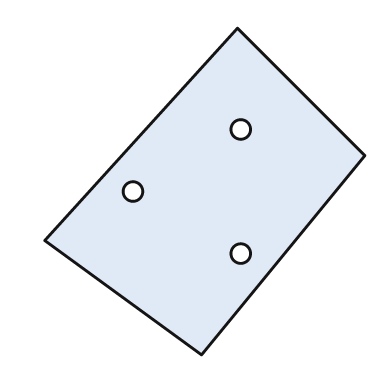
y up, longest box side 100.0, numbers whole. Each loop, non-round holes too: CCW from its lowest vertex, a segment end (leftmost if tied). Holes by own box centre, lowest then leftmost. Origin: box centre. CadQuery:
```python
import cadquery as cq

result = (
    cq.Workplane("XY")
    .moveTo(-1.0, -50.0)
    .lineTo(49.0, 11.0)
    .lineTo(10.0, 50.0)
    .lineTo(-49.0, -15.0)
    .close()
    .moveTo(11.0, -19.0)
    .circle(3.0)
    .moveTo(-22.0, 0.0)
    .circle(3.0)
    .moveTo(11.0, 19.0)
    .circle(3.0)
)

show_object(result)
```